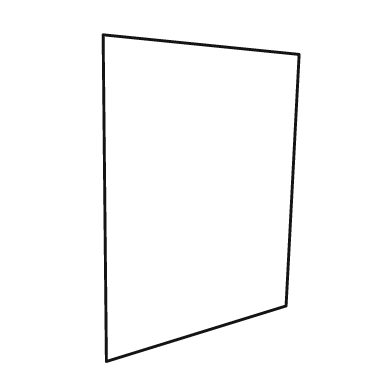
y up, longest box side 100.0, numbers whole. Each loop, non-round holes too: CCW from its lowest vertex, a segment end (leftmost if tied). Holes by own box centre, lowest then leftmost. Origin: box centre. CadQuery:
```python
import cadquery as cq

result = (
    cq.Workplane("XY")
    .moveTo(-29.0, -50.0)
    .lineTo(26.0, -33.0)
    .lineTo(30.0, 44.0)
    .lineTo(-30.0, 50.0)
    .close()
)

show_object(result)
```